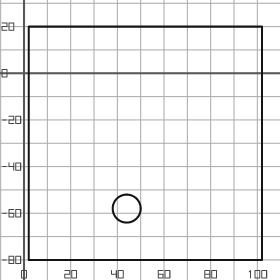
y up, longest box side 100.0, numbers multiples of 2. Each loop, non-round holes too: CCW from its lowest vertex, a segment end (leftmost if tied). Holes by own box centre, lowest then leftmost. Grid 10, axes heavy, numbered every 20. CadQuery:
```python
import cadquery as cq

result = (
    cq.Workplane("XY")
    .moveTo(2.0, -80.0)
    .lineTo(102.0, -80.0)
    .lineTo(102.0, 20.0)
    .lineTo(2.0, 20.0)
    .close()
    .moveTo(44.0, -58.0)
    .circle(6.0)
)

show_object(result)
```